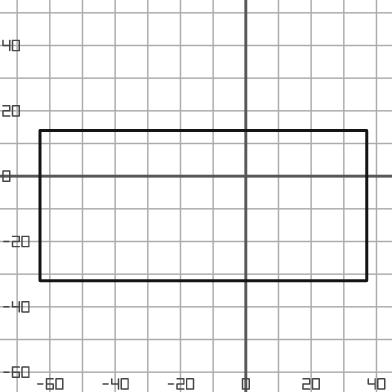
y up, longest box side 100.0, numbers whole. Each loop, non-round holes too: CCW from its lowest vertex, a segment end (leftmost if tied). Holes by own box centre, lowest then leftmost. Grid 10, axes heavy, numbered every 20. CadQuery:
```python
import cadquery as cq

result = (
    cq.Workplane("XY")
    .moveTo(-63.0, -32.0)
    .lineTo(37.0, -32.0)
    .lineTo(37.0, 14.0)
    .lineTo(-63.0, 14.0)
    .close()
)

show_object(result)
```